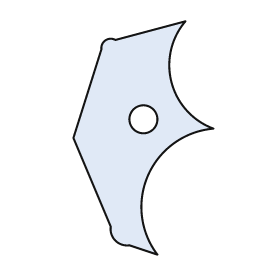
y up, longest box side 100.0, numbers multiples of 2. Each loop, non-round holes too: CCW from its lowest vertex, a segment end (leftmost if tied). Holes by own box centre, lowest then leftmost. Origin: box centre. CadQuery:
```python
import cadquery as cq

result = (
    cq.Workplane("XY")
    .moveTo(6.0, -50.0)
    .threePointArc((2.0, -16.0), (30.0, 4.0))
    .threePointArc((12.0, 24.0), (18.0, 50.0))
    .lineTo(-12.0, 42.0)
    .threePointArc((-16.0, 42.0), (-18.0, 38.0))
    .lineTo(-30.0, 0.0)
    .lineTo(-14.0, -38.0)
    .threePointArc((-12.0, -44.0), (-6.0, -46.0))
    .close()
    .moveTo(0.0, 8.0)
    .circle(6.0)
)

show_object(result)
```